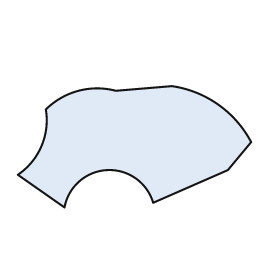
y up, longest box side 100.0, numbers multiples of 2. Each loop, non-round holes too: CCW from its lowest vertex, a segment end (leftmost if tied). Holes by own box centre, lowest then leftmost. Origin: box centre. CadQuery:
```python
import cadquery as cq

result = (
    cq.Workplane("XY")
    .moveTo(-30.0, -26.0)
    .threePointArc((-12.0, -10.0), (8.0, -24.0))
    .lineTo(40.0, -10.0)
    .lineTo(50.0, 2.0)
    .threePointArc((36.0, 18.0), (16.0, 26.0))
    .lineTo(-8.0, 24.0)
    .threePointArc((-24.0, 24.0), (-38.0, 16.0))
    .threePointArc((-40.0, 0.0), (-50.0, -12.0))
    .close()
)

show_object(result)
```